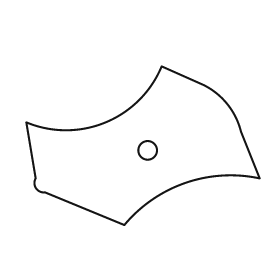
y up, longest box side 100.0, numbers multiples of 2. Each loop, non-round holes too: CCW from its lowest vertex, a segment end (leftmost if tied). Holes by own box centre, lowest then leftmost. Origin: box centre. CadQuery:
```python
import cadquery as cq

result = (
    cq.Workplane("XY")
    .moveTo(-8.0, -34.0)
    .threePointArc((18.0, -16.0), (50.0, -14.0))
    .lineTo(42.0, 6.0)
    .threePointArc((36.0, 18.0), (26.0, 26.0))
    .lineTo(8.0, 34.0)
    .threePointArc((-16.0, 10.0), (-50.0, 10.0))
    .lineTo(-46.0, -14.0)
    .threePointArc((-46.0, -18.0), (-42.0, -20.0))
    .close()
    .moveTo(2.0, -2.0)
    .circle(4.0)
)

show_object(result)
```